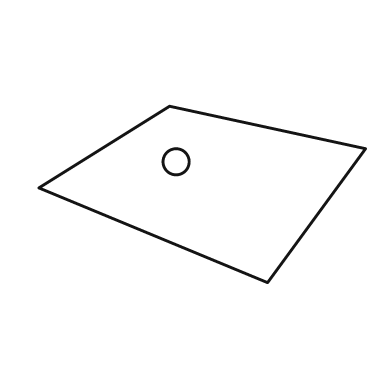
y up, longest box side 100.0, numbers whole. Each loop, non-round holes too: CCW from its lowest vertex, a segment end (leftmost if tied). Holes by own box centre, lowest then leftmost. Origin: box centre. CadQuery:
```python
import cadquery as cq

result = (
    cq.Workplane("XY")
    .moveTo(20.0, -27.0)
    .lineTo(50.0, 14.0)
    .lineTo(-10.0, 27.0)
    .lineTo(-50.0, 2.0)
    .close()
    .moveTo(-8.0, 10.0)
    .circle(4.0)
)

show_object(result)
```